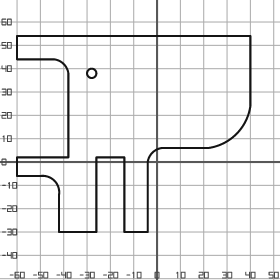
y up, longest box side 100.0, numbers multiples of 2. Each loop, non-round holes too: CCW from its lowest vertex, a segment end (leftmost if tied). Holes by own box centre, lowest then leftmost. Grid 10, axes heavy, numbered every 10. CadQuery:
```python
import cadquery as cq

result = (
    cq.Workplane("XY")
    .moveTo(-42.0, -30.0)
    .lineTo(-26.0, -30.0)
    .lineTo(-26.0, 2.0)
    .lineTo(-14.0, 2.0)
    .lineTo(-14.0, -30.0)
    .lineTo(-4.0, -30.0)
    .lineTo(-4.0, 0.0)
    .threePointArc((-2.0, 4.0), (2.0, 6.0))
    .lineTo(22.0, 6.0)
    .threePointArc((34.0, 12.0), (40.0, 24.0))
    .lineTo(40.0, 54.0)
    .lineTo(-60.0, 54.0)
    .lineTo(-60.0, 44.0)
    .lineTo(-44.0, 44.0)
    .threePointArc((-40.0, 42.0), (-38.0, 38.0))
    .lineTo(-38.0, 2.0)
    .lineTo(-60.0, 2.0)
    .lineTo(-60.0, -6.0)
    .lineTo(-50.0, -6.0)
    .threePointArc((-44.0, -8.0), (-42.0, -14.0))
    .close()
    .moveTo(-28.0, 38.0)
    .circle(2.0)
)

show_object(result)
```